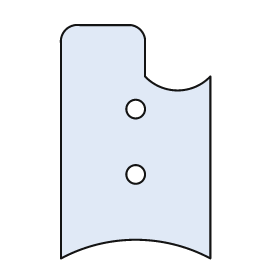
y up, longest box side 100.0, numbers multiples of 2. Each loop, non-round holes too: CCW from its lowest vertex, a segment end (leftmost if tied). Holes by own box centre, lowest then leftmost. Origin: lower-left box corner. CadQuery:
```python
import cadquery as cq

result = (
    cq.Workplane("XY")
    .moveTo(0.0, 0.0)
    .threePointArc((32.0, 8.0), (64.0, 0.0))
    .lineTo(64.0, 78.0)
    .threePointArc((50.0, 72.0), (36.0, 78.0))
    .lineTo(36.0, 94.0)
    .threePointArc((34.0, 98.0), (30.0, 100.0))
    .lineTo(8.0, 100.0)
    .threePointArc((2.0, 98.0), (0.0, 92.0))
    .close()
    .moveTo(32.0, 36.0)
    .circle(4.0)
    .moveTo(32.0, 64.0)
    .circle(4.0)
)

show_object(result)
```